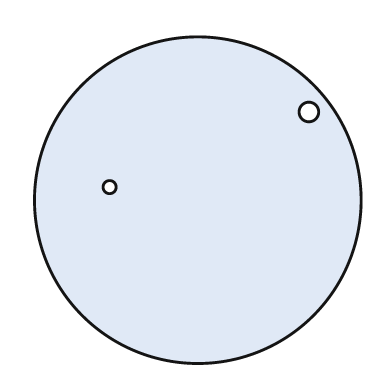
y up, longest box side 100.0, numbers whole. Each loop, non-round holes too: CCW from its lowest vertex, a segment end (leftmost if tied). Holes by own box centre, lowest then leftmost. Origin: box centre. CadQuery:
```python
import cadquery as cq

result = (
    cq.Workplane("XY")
    .moveTo(0.0, 0.0)
    .circle(50.0)
    .moveTo(-27.0, 4.0)
    .circle(2.0)
    .moveTo(34.0, 27.0)
    .circle(3.0)
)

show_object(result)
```